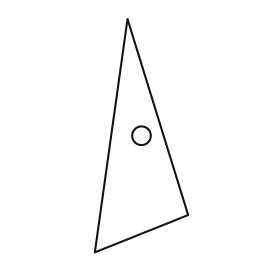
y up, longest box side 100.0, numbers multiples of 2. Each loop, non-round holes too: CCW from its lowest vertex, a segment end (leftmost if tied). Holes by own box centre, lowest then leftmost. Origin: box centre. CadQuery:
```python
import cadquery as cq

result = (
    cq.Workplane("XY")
    .moveTo(-20.0, -50.0)
    .lineTo(20.0, -34.0)
    .lineTo(-6.0, 50.0)
    .close()
    .moveTo(0.0, 0.0)
    .circle(4.0)
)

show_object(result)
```